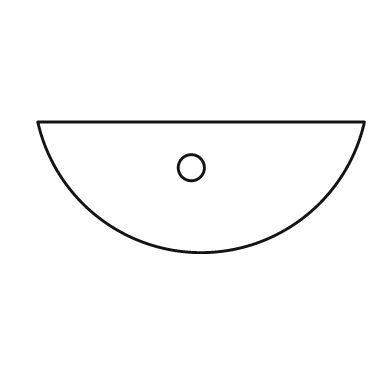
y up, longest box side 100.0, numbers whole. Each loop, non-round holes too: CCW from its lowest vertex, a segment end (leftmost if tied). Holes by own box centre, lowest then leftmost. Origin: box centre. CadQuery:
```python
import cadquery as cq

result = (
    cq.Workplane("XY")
    .moveTo(-50.0, 20.0)
    .threePointArc((0.0, -20.0), (50.0, 20.0))
    .close()
    .moveTo(-3.0, 6.0)
    .circle(4.0)
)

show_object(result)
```